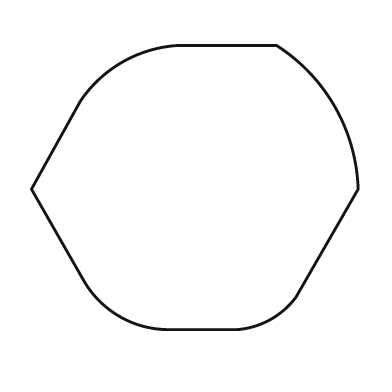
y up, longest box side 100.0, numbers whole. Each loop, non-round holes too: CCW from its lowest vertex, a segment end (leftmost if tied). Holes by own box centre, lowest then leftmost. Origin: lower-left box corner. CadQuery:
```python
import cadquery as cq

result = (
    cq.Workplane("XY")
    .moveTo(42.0, 0.0)
    .lineTo(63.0, 0.0)
    .threePointArc((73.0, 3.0), (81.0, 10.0))
    .lineTo(100.0, 43.0)
    .threePointArc((93.0, 68.0), (75.0, 87.0))
    .lineTo(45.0, 87.0)
    .threePointArc((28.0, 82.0), (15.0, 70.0))
    .lineTo(0.0, 43.0)
    .lineTo(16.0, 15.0)
    .threePointArc((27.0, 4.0), (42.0, 0.0))
    .close()
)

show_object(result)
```